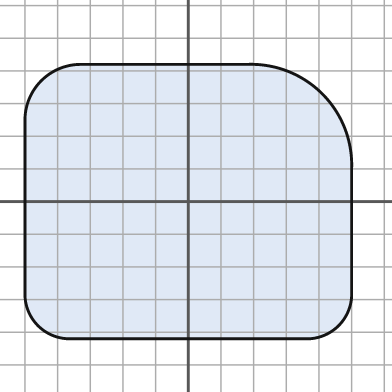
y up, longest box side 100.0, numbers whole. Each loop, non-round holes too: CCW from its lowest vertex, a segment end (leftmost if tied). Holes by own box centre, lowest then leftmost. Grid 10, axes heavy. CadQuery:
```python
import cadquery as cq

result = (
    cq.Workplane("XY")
    .moveTo(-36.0, -42.0)
    .lineTo(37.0, -42.0)
    .threePointArc((46.0, -38.0), (50.0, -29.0))
    .lineTo(50.0, 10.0)
    .threePointArc((41.0, 33.0), (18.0, 42.0))
    .lineTo(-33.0, 42.0)
    .threePointArc((-45.0, 37.0), (-50.0, 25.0))
    .lineTo(-50.0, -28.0)
    .threePointArc((-46.0, -38.0), (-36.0, -42.0))
    .close()
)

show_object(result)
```